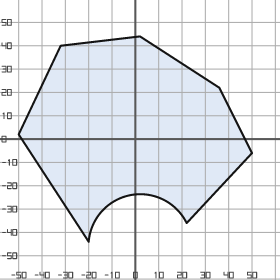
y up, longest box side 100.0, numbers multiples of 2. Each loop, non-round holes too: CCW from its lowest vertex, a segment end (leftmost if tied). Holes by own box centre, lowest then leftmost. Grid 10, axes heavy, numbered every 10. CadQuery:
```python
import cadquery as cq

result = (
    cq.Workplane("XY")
    .moveTo(-20.0, -44.0)
    .threePointArc((-2.0, -24.0), (22.0, -36.0))
    .lineTo(50.0, -6.0)
    .lineTo(36.0, 22.0)
    .lineTo(2.0, 44.0)
    .lineTo(-32.0, 40.0)
    .lineTo(-50.0, 2.0)
    .close()
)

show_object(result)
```